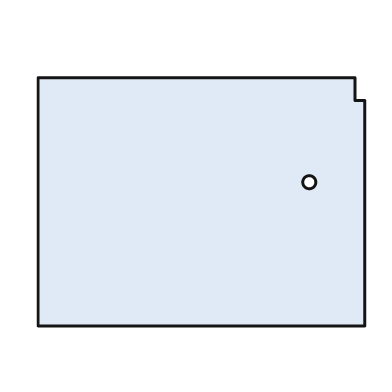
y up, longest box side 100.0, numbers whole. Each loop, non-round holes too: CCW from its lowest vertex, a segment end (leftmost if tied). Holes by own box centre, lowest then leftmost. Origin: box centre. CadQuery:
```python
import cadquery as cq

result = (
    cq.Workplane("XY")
    .moveTo(-50.0, -38.0)
    .lineTo(50.0, -38.0)
    .lineTo(50.0, 31.0)
    .lineTo(47.0, 31.0)
    .lineTo(47.0, 38.0)
    .lineTo(-50.0, 38.0)
    .close()
    .moveTo(33.0, 6.0)
    .circle(2.0)
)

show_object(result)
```